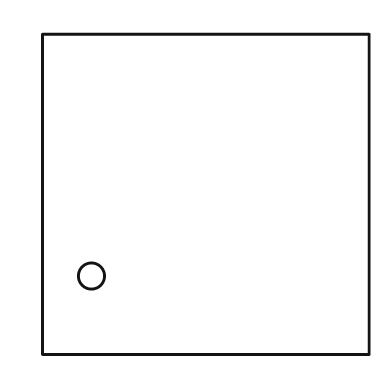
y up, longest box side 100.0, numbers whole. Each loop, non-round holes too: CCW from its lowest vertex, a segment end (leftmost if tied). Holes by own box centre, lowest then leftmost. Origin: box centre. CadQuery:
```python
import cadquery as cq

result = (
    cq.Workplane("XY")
    .moveTo(-50.0, -49.0)
    .lineTo(50.0, -49.0)
    .lineTo(50.0, 49.0)
    .lineTo(-50.0, 49.0)
    .close()
    .moveTo(-35.0, -25.0)
    .circle(4.0)
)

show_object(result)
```